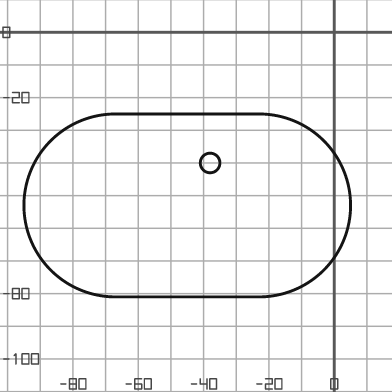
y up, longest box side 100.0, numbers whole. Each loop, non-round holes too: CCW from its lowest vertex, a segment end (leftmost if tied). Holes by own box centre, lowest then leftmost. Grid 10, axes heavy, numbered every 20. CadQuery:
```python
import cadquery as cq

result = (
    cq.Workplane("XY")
    .moveTo(-67.0, -81.0)
    .lineTo(-23.0, -81.0)
    .threePointArc((5.0, -53.0), (-23.0, -25.0))
    .lineTo(-67.0, -25.0)
    .threePointArc((-95.0, -53.0), (-67.0, -81.0))
    .close()
    .moveTo(-38.0, -40.0)
    .circle(3.0)
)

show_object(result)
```